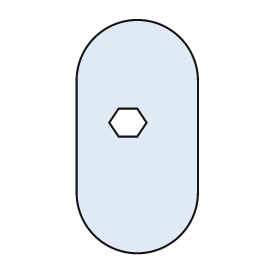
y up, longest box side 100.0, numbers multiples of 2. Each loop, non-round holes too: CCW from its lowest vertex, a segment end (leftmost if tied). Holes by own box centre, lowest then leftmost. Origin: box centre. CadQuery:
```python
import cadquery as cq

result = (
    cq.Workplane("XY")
    .moveTo(-26.0, -24.0)
    .threePointArc((0.0, -50.0), (26.0, -24.0))
    .lineTo(26.0, 24.0)
    .threePointArc((0.0, 50.0), (-26.0, 24.0))
    .close()
    .moveTo(-8.0, 0.0)
    .lineTo(0.0, 0.0)
    .lineTo(4.0, 6.0)
    .lineTo(0.0, 12.0)
    .lineTo(-8.0, 12.0)
    .lineTo(-12.0, 6.0)
    .close()
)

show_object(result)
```